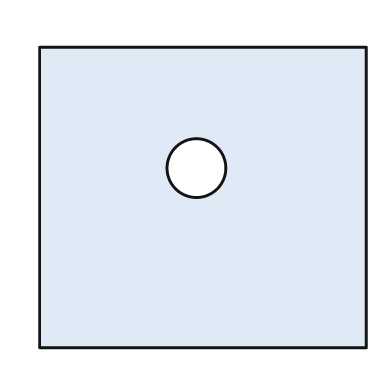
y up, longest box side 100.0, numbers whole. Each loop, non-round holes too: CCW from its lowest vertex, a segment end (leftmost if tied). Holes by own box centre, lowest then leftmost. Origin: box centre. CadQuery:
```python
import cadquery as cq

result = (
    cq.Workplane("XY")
    .moveTo(-50.0, -46.0)
    .lineTo(50.0, -46.0)
    .lineTo(50.0, 46.0)
    .lineTo(-50.0, 46.0)
    .close()
    .moveTo(-2.0, 9.0)
    .circle(9.0)
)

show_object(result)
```